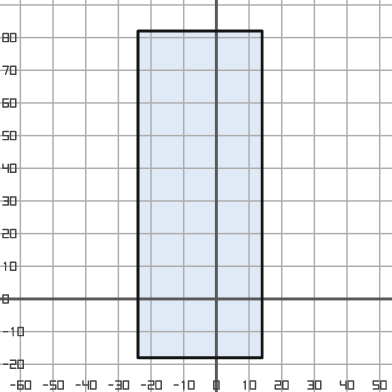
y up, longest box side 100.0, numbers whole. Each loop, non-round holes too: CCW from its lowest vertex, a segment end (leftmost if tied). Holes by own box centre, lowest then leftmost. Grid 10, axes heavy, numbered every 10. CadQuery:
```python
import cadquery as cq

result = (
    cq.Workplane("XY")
    .moveTo(-24.0, -18.0)
    .lineTo(14.0, -18.0)
    .lineTo(14.0, 82.0)
    .lineTo(-24.0, 82.0)
    .close()
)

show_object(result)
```